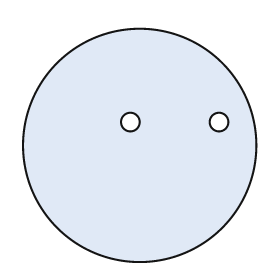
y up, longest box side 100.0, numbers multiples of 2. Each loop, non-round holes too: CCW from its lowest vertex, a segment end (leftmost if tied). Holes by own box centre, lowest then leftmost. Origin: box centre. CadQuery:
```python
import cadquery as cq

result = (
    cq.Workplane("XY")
    .moveTo(0.0, 0.0)
    .circle(50.0)
    .moveTo(-4.0, 10.0)
    .circle(4.0)
    .moveTo(34.0, 10.0)
    .circle(4.0)
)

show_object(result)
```